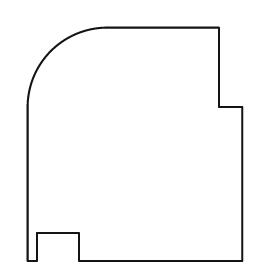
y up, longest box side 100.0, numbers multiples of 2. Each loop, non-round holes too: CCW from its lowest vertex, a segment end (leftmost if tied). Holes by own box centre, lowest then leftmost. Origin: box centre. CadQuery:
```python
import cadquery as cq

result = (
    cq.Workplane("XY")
    .moveTo(-46.0, -50.0)
    .lineTo(-42.0, -50.0)
    .lineTo(-42.0, -38.0)
    .lineTo(-24.0, -38.0)
    .lineTo(-24.0, -50.0)
    .lineTo(46.0, -50.0)
    .lineTo(46.0, 16.0)
    .lineTo(36.0, 16.0)
    .lineTo(36.0, 50.0)
    .lineTo(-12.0, 50.0)
    .threePointArc((-36.0, 40.0), (-46.0, 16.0))
    .close()
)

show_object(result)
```